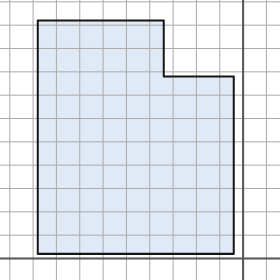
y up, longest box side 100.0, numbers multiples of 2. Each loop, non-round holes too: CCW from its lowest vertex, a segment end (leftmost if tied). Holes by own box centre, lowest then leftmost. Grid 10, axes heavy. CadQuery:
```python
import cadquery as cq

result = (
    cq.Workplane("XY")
    .moveTo(-88.0, 2.0)
    .lineTo(-4.0, 2.0)
    .lineTo(-4.0, 78.0)
    .lineTo(-34.0, 78.0)
    .lineTo(-34.0, 102.0)
    .lineTo(-88.0, 102.0)
    .close()
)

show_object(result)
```